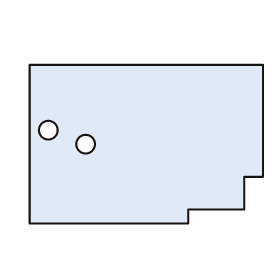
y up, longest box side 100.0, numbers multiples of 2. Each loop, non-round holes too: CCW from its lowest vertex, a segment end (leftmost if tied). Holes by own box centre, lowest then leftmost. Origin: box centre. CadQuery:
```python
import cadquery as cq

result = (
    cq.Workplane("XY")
    .moveTo(-50.0, -34.0)
    .lineTo(18.0, -34.0)
    .lineTo(18.0, -28.0)
    .lineTo(42.0, -28.0)
    .lineTo(42.0, -14.0)
    .lineTo(50.0, -14.0)
    .lineTo(50.0, 34.0)
    .lineTo(-50.0, 34.0)
    .close()
    .moveTo(-26.0, 0.0)
    .circle(4.0)
    .moveTo(-42.0, 6.0)
    .circle(4.0)
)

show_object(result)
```